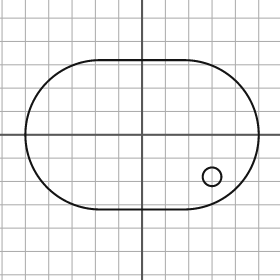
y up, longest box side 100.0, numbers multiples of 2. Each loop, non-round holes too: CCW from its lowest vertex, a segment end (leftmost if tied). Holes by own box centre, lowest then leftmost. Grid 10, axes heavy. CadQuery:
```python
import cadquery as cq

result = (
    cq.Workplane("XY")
    .moveTo(-18.0, -32.0)
    .lineTo(18.0, -32.0)
    .threePointArc((50.0, 0.0), (18.0, 32.0))
    .lineTo(-18.0, 32.0)
    .threePointArc((-50.0, 0.0), (-18.0, -32.0))
    .close()
    .moveTo(30.0, -18.0)
    .circle(4.0)
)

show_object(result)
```